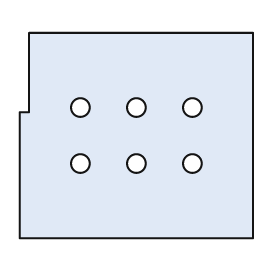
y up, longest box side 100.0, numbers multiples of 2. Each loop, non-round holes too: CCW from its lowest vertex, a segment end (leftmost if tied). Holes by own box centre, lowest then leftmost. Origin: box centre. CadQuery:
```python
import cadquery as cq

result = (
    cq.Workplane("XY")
    .moveTo(-50.0, -44.0)
    .lineTo(50.0, -44.0)
    .lineTo(50.0, 44.0)
    .lineTo(-46.0, 44.0)
    .lineTo(-46.0, 10.0)
    .lineTo(-50.0, 10.0)
    .close()
    .moveTo(-24.0, -12.0)
    .circle(4.0)
    .moveTo(0.0, -12.0)
    .circle(4.0)
    .moveTo(24.0, -12.0)
    .circle(4.0)
    .moveTo(-24.0, 12.0)
    .circle(4.0)
    .moveTo(0.0, 12.0)
    .circle(4.0)
    .moveTo(24.0, 12.0)
    .circle(4.0)
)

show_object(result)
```